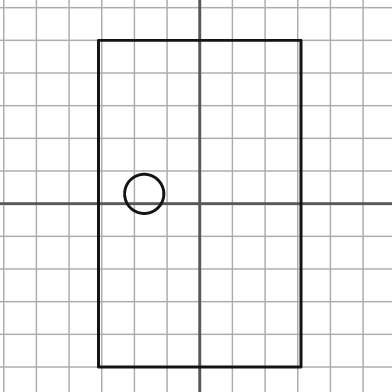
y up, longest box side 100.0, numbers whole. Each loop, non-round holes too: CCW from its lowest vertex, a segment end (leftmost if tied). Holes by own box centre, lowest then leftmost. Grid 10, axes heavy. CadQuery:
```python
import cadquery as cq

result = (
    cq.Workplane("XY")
    .moveTo(-31.0, -50.0)
    .lineTo(31.0, -50.0)
    .lineTo(31.0, 50.0)
    .lineTo(-31.0, 50.0)
    .close()
    .moveTo(-17.0, 3.0)
    .circle(6.0)
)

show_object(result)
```